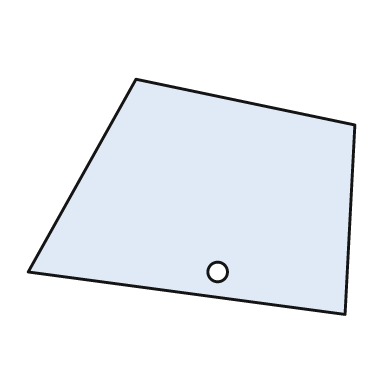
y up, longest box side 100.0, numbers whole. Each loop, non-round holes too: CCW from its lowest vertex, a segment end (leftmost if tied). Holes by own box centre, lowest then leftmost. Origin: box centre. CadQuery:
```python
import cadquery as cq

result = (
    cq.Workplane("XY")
    .moveTo(47.0, -36.0)
    .lineTo(50.0, 22.0)
    .lineTo(-17.0, 36.0)
    .lineTo(-50.0, -23.0)
    .close()
    .moveTo(8.0, -23.0)
    .circle(3.0)
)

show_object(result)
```